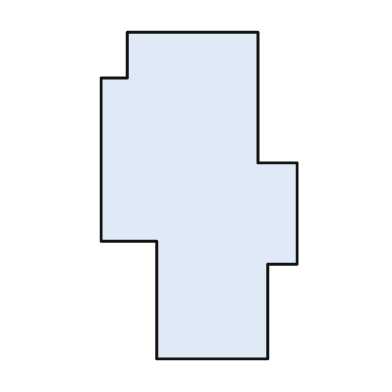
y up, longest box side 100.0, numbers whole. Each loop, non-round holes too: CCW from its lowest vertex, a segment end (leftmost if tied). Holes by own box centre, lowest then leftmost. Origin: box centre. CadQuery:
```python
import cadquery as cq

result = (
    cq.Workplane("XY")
    .moveTo(-13.0, -50.0)
    .lineTo(21.0, -50.0)
    .lineTo(21.0, -21.0)
    .lineTo(30.0, -21.0)
    .lineTo(30.0, 10.0)
    .lineTo(18.0, 10.0)
    .lineTo(18.0, 50.0)
    .lineTo(-22.0, 50.0)
    .lineTo(-22.0, 36.0)
    .lineTo(-30.0, 36.0)
    .lineTo(-30.0, -14.0)
    .lineTo(-13.0, -14.0)
    .close()
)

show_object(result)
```